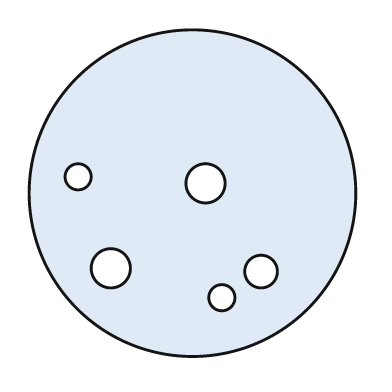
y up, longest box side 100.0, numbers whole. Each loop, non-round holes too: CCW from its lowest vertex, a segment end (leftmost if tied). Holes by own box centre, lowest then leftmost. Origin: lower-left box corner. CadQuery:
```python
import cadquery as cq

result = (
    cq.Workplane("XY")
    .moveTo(50.0, 50.0)
    .circle(50.0)
    .moveTo(59.0, 18.0)
    .circle(4.0)
    .moveTo(71.0, 26.0)
    .circle(5.0)
    .moveTo(25.0, 27.0)
    .circle(6.0)
    .moveTo(54.0, 53.0)
    .circle(6.0)
    .moveTo(15.0, 55.0)
    .circle(4.0)
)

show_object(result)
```